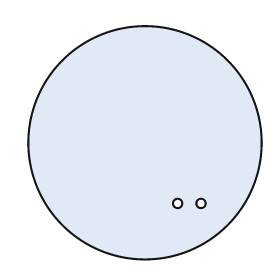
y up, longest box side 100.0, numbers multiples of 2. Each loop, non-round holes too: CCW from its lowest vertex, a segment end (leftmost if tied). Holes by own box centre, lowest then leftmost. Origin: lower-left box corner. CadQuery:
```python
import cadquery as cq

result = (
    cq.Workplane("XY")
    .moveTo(50.0, 50.0)
    .circle(50.0)
    .moveTo(64.0, 24.0)
    .circle(2.0)
    .moveTo(74.0, 24.0)
    .circle(2.0)
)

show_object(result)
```